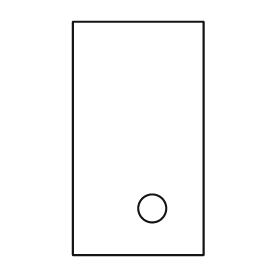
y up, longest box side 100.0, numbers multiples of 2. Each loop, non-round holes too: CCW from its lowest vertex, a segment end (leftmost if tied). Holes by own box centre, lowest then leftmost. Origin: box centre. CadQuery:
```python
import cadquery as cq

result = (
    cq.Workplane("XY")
    .moveTo(-28.0, -50.0)
    .lineTo(28.0, -50.0)
    .lineTo(28.0, 50.0)
    .lineTo(-28.0, 50.0)
    .close()
    .moveTo(6.0, -30.0)
    .circle(6.0)
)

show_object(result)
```